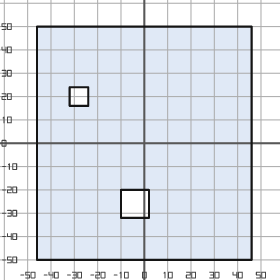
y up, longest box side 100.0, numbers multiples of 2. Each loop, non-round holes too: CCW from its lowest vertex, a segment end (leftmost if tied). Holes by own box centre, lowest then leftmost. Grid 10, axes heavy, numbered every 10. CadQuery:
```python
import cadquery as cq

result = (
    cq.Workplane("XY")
    .moveTo(-46.0, -50.0)
    .lineTo(46.0, -50.0)
    .lineTo(46.0, 50.0)
    .lineTo(-46.0, 50.0)
    .close()
    .moveTo(-10.0, -32.0)
    .lineTo(2.0, -32.0)
    .lineTo(2.0, -20.0)
    .lineTo(-10.0, -20.0)
    .close()
    .moveTo(-32.0, 16.0)
    .lineTo(-24.0, 16.0)
    .lineTo(-24.0, 24.0)
    .lineTo(-32.0, 24.0)
    .close()
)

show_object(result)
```